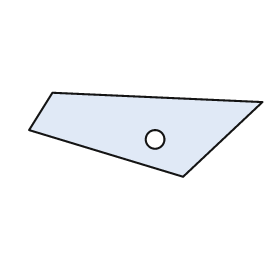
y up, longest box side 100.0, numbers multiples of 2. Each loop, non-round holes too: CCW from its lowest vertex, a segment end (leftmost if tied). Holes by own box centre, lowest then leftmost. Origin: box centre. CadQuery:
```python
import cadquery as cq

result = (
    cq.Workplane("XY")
    .moveTo(16.0, -18.0)
    .lineTo(50.0, 14.0)
    .lineTo(-40.0, 18.0)
    .lineTo(-50.0, 2.0)
    .close()
    .moveTo(4.0, -2.0)
    .circle(4.0)
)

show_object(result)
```